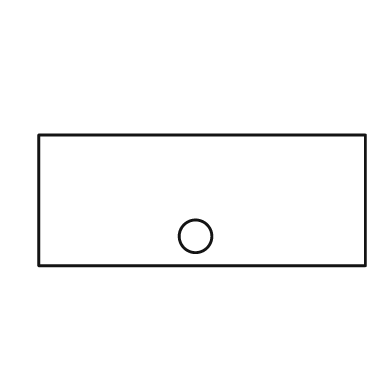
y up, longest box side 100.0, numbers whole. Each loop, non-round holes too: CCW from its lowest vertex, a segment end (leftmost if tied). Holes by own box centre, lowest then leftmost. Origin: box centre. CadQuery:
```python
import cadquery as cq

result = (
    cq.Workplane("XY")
    .moveTo(-50.0, -20.0)
    .lineTo(50.0, -20.0)
    .lineTo(50.0, 20.0)
    .lineTo(-50.0, 20.0)
    .close()
    .moveTo(-2.0, -11.0)
    .circle(5.0)
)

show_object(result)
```